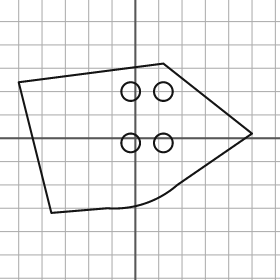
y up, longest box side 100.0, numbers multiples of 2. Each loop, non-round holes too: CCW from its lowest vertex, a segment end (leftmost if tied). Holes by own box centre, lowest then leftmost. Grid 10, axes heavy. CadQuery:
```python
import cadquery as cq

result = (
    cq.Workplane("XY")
    .moveTo(-36.0, -32.0)
    .lineTo(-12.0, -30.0)
    .threePointArc((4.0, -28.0), (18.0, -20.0))
    .lineTo(50.0, 2.0)
    .lineTo(12.0, 32.0)
    .lineTo(-50.0, 24.0)
    .close()
    .moveTo(-2.0, -2.0)
    .circle(4.0)
    .moveTo(12.0, -2.0)
    .circle(4.0)
    .moveTo(-2.0, 20.0)
    .circle(4.0)
    .moveTo(12.0, 20.0)
    .circle(4.0)
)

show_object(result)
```